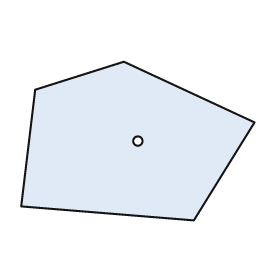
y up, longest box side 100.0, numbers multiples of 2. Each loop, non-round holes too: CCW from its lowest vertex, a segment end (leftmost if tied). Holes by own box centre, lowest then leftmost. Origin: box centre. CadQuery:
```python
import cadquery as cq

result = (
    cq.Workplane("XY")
    .moveTo(24.0, -34.0)
    .lineTo(50.0, 8.0)
    .lineTo(-6.0, 34.0)
    .lineTo(-44.0, 22.0)
    .lineTo(-50.0, -28.0)
    .close()
    .moveTo(0.0, 0.0)
    .circle(2.0)
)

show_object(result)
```